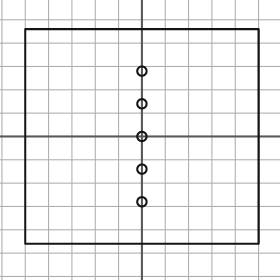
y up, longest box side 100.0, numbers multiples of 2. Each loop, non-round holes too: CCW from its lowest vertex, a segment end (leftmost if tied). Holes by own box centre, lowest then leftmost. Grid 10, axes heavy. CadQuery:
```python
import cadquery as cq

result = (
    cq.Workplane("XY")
    .moveTo(-50.0, -46.0)
    .lineTo(50.0, -46.0)
    .lineTo(50.0, 46.0)
    .lineTo(-50.0, 46.0)
    .close()
    .moveTo(0.0, -28.0)
    .circle(2.0)
    .moveTo(0.0, -14.0)
    .circle(2.0)
    .moveTo(0.0, 0.0)
    .circle(2.0)
    .moveTo(0.0, 14.0)
    .circle(2.0)
    .moveTo(0.0, 28.0)
    .circle(2.0)
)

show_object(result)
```